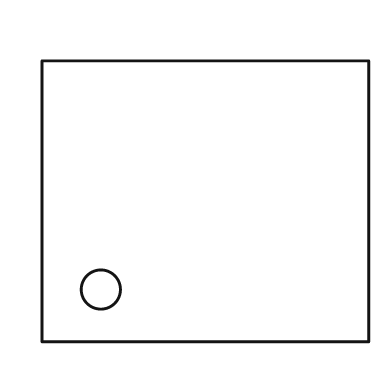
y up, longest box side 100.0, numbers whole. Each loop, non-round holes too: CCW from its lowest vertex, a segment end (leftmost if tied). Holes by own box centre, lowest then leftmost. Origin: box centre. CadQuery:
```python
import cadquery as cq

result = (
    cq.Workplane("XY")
    .moveTo(-50.0, -43.0)
    .lineTo(50.0, -43.0)
    .lineTo(50.0, 43.0)
    .lineTo(-50.0, 43.0)
    .close()
    .moveTo(-32.0, -27.0)
    .circle(6.0)
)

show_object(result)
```